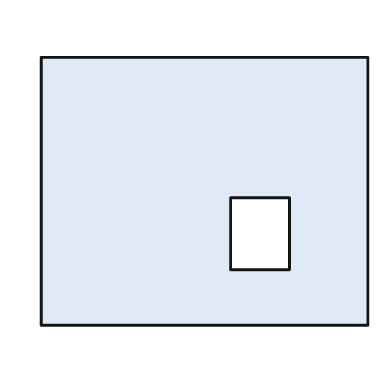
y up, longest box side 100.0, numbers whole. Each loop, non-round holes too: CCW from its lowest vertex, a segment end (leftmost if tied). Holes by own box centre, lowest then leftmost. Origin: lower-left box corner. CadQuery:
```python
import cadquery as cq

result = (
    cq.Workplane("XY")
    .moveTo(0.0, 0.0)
    .lineTo(100.0, 0.0)
    .lineTo(100.0, 82.0)
    .lineTo(0.0, 82.0)
    .close()
    .moveTo(58.0, 17.0)
    .lineTo(76.0, 17.0)
    .lineTo(76.0, 39.0)
    .lineTo(58.0, 39.0)
    .close()
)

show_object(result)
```